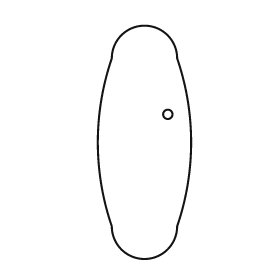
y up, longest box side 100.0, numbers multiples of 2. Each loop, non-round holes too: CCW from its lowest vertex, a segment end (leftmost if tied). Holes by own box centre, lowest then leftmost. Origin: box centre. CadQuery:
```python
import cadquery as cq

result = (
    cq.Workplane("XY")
    .moveTo(-14.0, -36.0)
    .threePointArc((0.0, -50.0), (14.0, -36.0))
    .threePointArc((20.0, 0.0), (14.0, 36.0))
    .threePointArc((0.0, 50.0), (-14.0, 36.0))
    .threePointArc((-20.0, 0.0), (-14.0, -36.0))
    .close()
    .moveTo(10.0, 12.0)
    .circle(2.0)
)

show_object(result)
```